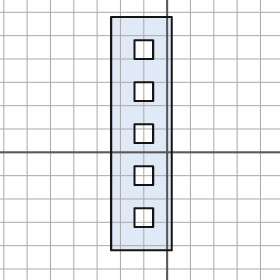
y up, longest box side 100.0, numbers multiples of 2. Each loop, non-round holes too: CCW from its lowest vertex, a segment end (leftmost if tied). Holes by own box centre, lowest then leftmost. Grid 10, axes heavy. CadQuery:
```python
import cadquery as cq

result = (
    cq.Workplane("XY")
    .moveTo(-24.0, -42.0)
    .lineTo(2.0, -42.0)
    .lineTo(2.0, 58.0)
    .lineTo(-24.0, 58.0)
    .close()
    .moveTo(-14.0, -32.0)
    .lineTo(-6.0, -32.0)
    .lineTo(-6.0, -24.0)
    .lineTo(-14.0, -24.0)
    .close()
    .moveTo(-14.0, -14.0)
    .lineTo(-6.0, -14.0)
    .lineTo(-6.0, -6.0)
    .lineTo(-14.0, -6.0)
    .close()
    .moveTo(-14.0, 4.0)
    .lineTo(-6.0, 4.0)
    .lineTo(-6.0, 12.0)
    .lineTo(-14.0, 12.0)
    .close()
    .moveTo(-14.0, 22.0)
    .lineTo(-6.0, 22.0)
    .lineTo(-6.0, 30.0)
    .lineTo(-14.0, 30.0)
    .close()
    .moveTo(-14.0, 40.0)
    .lineTo(-6.0, 40.0)
    .lineTo(-6.0, 48.0)
    .lineTo(-14.0, 48.0)
    .close()
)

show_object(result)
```